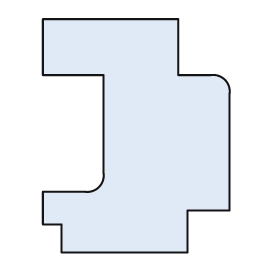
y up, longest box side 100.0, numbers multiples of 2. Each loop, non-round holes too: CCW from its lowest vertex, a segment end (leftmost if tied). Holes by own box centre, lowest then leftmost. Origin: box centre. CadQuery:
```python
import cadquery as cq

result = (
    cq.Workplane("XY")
    .moveTo(-32.0, -50.0)
    .lineTo(22.0, -50.0)
    .lineTo(22.0, -32.0)
    .lineTo(40.0, -32.0)
    .lineTo(40.0, 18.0)
    .threePointArc((38.0, 24.0), (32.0, 26.0))
    .lineTo(18.0, 26.0)
    .lineTo(18.0, 50.0)
    .lineTo(-40.0, 50.0)
    .lineTo(-40.0, 26.0)
    .lineTo(-14.0, 26.0)
    .lineTo(-14.0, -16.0)
    .threePointArc((-16.0, -22.0), (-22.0, -24.0))
    .lineTo(-40.0, -24.0)
    .lineTo(-40.0, -38.0)
    .lineTo(-32.0, -38.0)
    .close()
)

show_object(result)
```